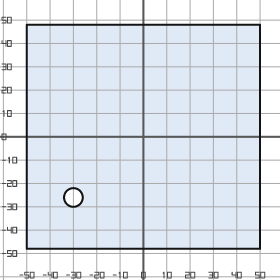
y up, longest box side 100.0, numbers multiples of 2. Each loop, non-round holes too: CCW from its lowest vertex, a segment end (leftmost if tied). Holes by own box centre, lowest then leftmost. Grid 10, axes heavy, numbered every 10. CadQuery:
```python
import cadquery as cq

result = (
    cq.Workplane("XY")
    .moveTo(-50.0, -48.0)
    .lineTo(50.0, -48.0)
    .lineTo(50.0, 48.0)
    .lineTo(-50.0, 48.0)
    .close()
    .moveTo(-30.0, -26.0)
    .circle(4.0)
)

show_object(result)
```